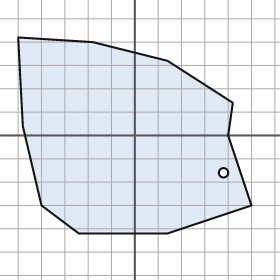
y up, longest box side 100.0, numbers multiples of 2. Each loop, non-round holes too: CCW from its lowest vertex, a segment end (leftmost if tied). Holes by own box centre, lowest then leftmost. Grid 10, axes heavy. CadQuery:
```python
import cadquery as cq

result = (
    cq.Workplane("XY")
    .moveTo(-24.0, -42.0)
    .lineTo(14.0, -42.0)
    .lineTo(50.0, -30.0)
    .lineTo(40.0, 0.0)
    .lineTo(42.0, 14.0)
    .lineTo(14.0, 32.0)
    .lineTo(-18.0, 40.0)
    .lineTo(-50.0, 42.0)
    .lineTo(-48.0, 4.0)
    .lineTo(-40.0, -30.0)
    .close()
    .moveTo(38.0, -16.0)
    .circle(2.0)
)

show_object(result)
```